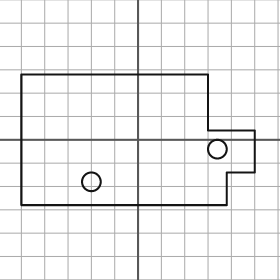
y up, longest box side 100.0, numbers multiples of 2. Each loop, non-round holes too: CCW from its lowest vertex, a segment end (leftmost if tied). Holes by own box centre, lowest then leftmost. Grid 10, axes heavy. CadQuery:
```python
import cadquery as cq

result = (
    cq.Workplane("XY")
    .moveTo(-50.0, -28.0)
    .lineTo(38.0, -28.0)
    .lineTo(38.0, -14.0)
    .lineTo(50.0, -14.0)
    .lineTo(50.0, 4.0)
    .lineTo(30.0, 4.0)
    .lineTo(30.0, 28.0)
    .lineTo(-50.0, 28.0)
    .close()
    .moveTo(-20.0, -18.0)
    .circle(4.0)
    .moveTo(34.0, -4.0)
    .circle(4.0)
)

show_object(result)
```